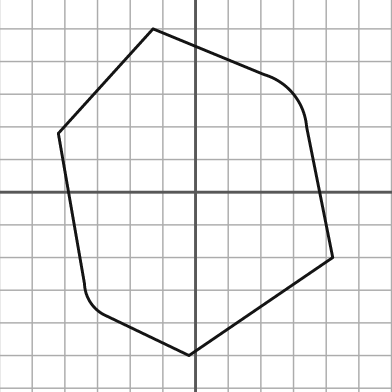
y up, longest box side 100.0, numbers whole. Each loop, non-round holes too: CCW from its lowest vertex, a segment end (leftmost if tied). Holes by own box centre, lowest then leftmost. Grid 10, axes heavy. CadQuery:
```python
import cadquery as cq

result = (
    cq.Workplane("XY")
    .moveTo(-2.0, -50.0)
    .lineTo(42.0, -20.0)
    .lineTo(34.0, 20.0)
    .threePointArc((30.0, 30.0), (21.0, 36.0))
    .lineTo(-13.0, 50.0)
    .lineTo(-42.0, 18.0)
    .lineTo(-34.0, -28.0)
    .threePointArc((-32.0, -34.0), (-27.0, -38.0))
    .close()
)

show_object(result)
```